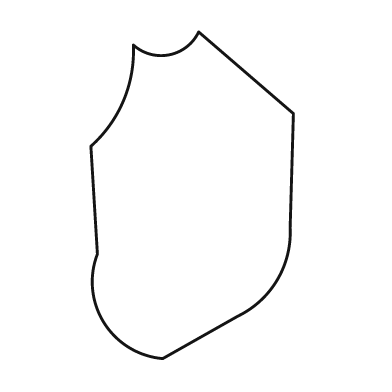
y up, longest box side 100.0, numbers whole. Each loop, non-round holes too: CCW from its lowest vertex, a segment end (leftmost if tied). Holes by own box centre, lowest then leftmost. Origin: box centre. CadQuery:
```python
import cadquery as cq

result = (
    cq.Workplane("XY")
    .moveTo(-9.0, -50.0)
    .lineTo(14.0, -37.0)
    .threePointArc((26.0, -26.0), (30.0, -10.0))
    .lineTo(31.0, 25.0)
    .lineTo(2.0, 50.0)
    .threePointArc((-7.0, 43.0), (-18.0, 46.0))
    .threePointArc((-21.0, 29.0), (-31.0, 15.0))
    .lineTo(-29.0, -18.0)
    .threePointArc((-27.0, -39.0), (-9.0, -50.0))
    .close()
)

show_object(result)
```